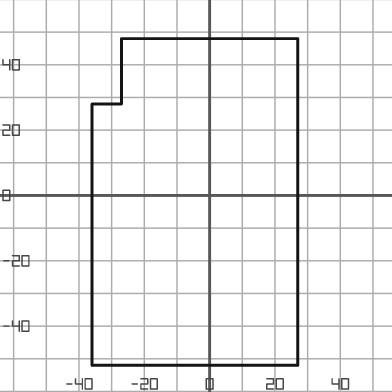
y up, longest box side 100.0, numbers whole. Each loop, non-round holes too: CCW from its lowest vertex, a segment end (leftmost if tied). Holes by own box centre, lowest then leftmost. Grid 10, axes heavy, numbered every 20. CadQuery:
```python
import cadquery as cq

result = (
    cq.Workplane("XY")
    .moveTo(-36.0, -52.0)
    .lineTo(27.0, -52.0)
    .lineTo(27.0, 48.0)
    .lineTo(-27.0, 48.0)
    .lineTo(-27.0, 28.0)
    .lineTo(-36.0, 28.0)
    .close()
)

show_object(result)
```